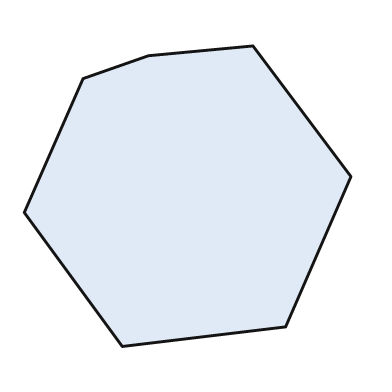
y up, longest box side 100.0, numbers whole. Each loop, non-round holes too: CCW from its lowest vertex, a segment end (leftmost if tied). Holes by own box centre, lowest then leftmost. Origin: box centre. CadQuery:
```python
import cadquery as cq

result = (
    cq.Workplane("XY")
    .moveTo(-20.0, -46.0)
    .lineTo(30.0, -40.0)
    .lineTo(50.0, 6.0)
    .lineTo(20.0, 46.0)
    .lineTo(-12.0, 43.0)
    .lineTo(-32.0, 36.0)
    .lineTo(-50.0, -5.0)
    .close()
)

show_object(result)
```